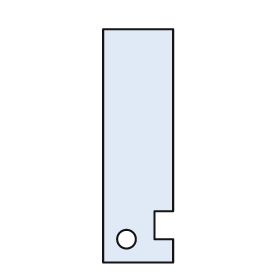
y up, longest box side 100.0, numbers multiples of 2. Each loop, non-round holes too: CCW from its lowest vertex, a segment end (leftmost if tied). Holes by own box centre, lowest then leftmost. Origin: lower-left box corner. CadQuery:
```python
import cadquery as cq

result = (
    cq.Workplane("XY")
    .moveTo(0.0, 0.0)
    .lineTo(30.0, 0.0)
    .lineTo(30.0, 10.0)
    .lineTo(22.0, 10.0)
    .lineTo(22.0, 22.0)
    .lineTo(30.0, 22.0)
    .lineTo(30.0, 100.0)
    .lineTo(0.0, 100.0)
    .close()
    .moveTo(10.0, 10.0)
    .circle(4.0)
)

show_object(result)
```